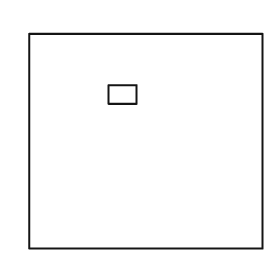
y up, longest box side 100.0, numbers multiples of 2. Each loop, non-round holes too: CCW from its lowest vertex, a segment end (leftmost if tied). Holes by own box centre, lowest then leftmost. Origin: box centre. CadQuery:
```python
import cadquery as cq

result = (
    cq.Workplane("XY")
    .moveTo(-50.0, -46.0)
    .lineTo(50.0, -46.0)
    .lineTo(50.0, 46.0)
    .lineTo(-50.0, 46.0)
    .close()
    .moveTo(-16.0, 16.0)
    .lineTo(-4.0, 16.0)
    .lineTo(-4.0, 24.0)
    .lineTo(-16.0, 24.0)
    .close()
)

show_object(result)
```